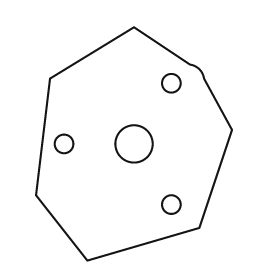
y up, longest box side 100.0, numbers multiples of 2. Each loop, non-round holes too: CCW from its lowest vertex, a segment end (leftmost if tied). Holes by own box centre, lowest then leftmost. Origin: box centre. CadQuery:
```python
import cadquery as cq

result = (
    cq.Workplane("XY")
    .moveTo(-20.0, -50.0)
    .lineTo(28.0, -36.0)
    .lineTo(42.0, 6.0)
    .lineTo(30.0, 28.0)
    .threePointArc((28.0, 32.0), (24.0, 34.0))
    .lineTo(0.0, 50.0)
    .lineTo(-36.0, 28.0)
    .lineTo(-42.0, -22.0)
    .close()
    .moveTo(16.0, -26.0)
    .circle(4.0)
    .moveTo(-30.0, 0.0)
    .circle(4.0)
    .moveTo(0.0, 0.0)
    .circle(8.0)
    .moveTo(16.0, 26.0)
    .circle(4.0)
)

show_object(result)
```